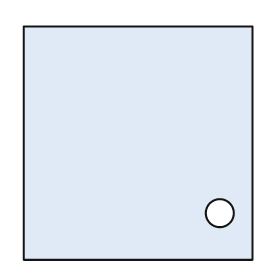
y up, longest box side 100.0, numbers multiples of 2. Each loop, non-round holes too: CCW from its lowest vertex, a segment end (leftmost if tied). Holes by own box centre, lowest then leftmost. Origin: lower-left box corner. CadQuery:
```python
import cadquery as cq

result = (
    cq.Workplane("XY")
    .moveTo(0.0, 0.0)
    .lineTo(98.0, 0.0)
    .lineTo(98.0, 100.0)
    .lineTo(0.0, 100.0)
    .close()
    .moveTo(84.0, 20.0)
    .circle(6.0)
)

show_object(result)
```